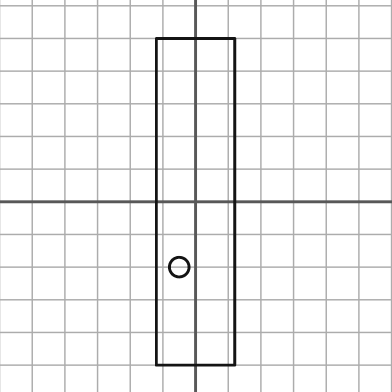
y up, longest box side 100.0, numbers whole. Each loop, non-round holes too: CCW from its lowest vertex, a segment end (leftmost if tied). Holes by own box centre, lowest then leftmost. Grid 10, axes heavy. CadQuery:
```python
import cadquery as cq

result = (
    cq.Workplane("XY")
    .moveTo(-12.0, -50.0)
    .lineTo(12.0, -50.0)
    .lineTo(12.0, 50.0)
    .lineTo(-12.0, 50.0)
    .close()
    .moveTo(-5.0, -20.0)
    .circle(3.0)
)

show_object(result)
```